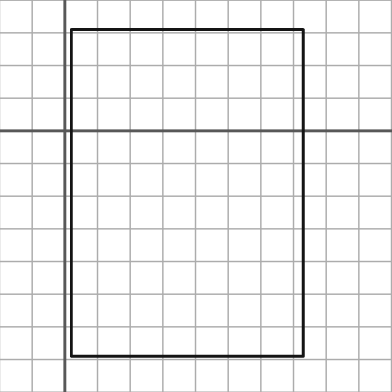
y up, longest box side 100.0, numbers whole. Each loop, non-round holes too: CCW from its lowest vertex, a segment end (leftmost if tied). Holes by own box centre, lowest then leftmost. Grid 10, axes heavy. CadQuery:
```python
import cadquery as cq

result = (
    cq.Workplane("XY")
    .moveTo(2.0, -69.0)
    .lineTo(73.0, -69.0)
    .lineTo(73.0, 31.0)
    .lineTo(2.0, 31.0)
    .close()
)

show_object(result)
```